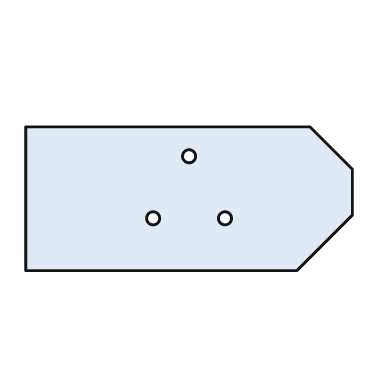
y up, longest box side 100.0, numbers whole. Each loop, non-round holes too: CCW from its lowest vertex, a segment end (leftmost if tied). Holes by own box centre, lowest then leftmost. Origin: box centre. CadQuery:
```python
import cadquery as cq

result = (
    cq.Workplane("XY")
    .moveTo(-50.0, -22.0)
    .lineTo(33.0, -22.0)
    .lineTo(50.0, -5.0)
    .lineTo(50.0, 9.0)
    .lineTo(37.0, 22.0)
    .lineTo(-50.0, 22.0)
    .close()
    .moveTo(-11.0, -6.0)
    .circle(2.0)
    .moveTo(11.0, -6.0)
    .circle(2.0)
    .moveTo(0.0, 13.0)
    .circle(2.0)
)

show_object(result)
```